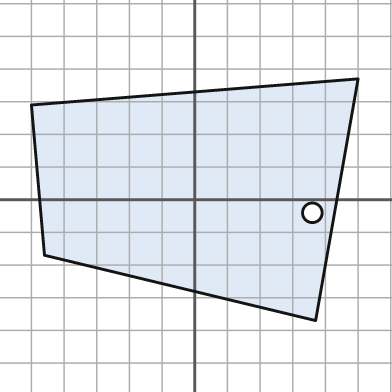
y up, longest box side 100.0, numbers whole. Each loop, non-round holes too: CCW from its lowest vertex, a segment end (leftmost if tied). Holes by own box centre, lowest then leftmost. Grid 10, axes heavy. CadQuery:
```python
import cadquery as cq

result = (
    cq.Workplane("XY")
    .moveTo(37.0, -37.0)
    .lineTo(50.0, 37.0)
    .lineTo(-50.0, 29.0)
    .lineTo(-46.0, -17.0)
    .close()
    .moveTo(36.0, -4.0)
    .circle(3.0)
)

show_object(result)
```